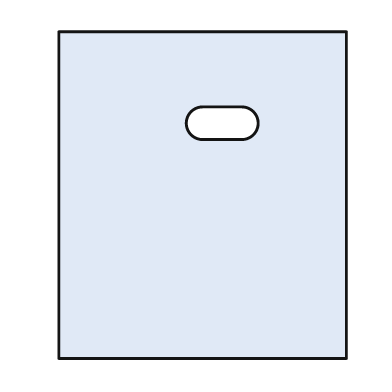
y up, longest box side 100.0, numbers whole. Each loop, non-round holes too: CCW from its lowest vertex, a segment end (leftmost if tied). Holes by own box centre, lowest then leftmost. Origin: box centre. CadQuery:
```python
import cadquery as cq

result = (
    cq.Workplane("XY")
    .moveTo(-44.0, -50.0)
    .lineTo(44.0, -50.0)
    .lineTo(44.0, 50.0)
    .lineTo(-44.0, 50.0)
    .close()
    .moveTo(0.0, 17.0)
    .lineTo(12.0, 17.0)
    .threePointArc((17.0, 22.0), (12.0, 27.0))
    .lineTo(0.0, 27.0)
    .threePointArc((-5.0, 22.0), (0.0, 17.0))
    .close()
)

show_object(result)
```